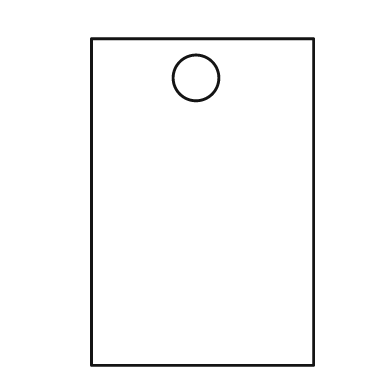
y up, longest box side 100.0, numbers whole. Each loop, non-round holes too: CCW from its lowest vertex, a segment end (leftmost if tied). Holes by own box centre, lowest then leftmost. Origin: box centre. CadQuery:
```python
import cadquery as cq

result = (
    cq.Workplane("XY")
    .moveTo(-34.0, -50.0)
    .lineTo(34.0, -50.0)
    .lineTo(34.0, 50.0)
    .lineTo(-34.0, 50.0)
    .close()
    .moveTo(-2.0, 38.0)
    .circle(7.0)
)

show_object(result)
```